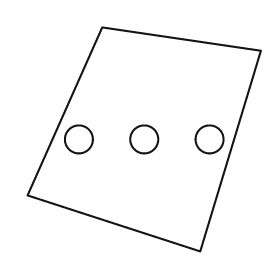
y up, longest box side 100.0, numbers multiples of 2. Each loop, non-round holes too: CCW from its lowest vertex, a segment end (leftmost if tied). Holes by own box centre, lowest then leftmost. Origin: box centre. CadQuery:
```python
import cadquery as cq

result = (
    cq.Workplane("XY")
    .moveTo(24.0, -48.0)
    .lineTo(50.0, 38.0)
    .lineTo(-18.0, 48.0)
    .lineTo(-50.0, -24.0)
    .close()
    .moveTo(-28.0, 0.0)
    .circle(6.0)
    .moveTo(0.0, 0.0)
    .circle(6.0)
    .moveTo(28.0, 0.0)
    .circle(6.0)
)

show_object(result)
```